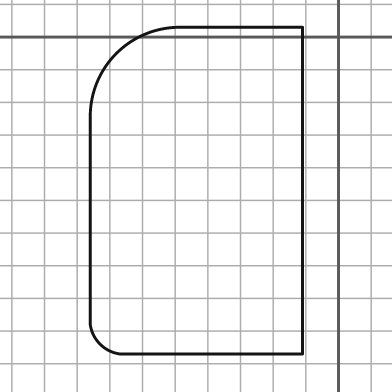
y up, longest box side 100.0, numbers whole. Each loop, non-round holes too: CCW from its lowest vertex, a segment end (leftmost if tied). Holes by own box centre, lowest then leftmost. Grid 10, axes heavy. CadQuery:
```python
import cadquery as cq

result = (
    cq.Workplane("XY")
    .moveTo(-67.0, -97.0)
    .lineTo(-11.0, -97.0)
    .lineTo(-11.0, 3.0)
    .lineTo(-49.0, 3.0)
    .threePointArc((-68.0, -5.0), (-76.0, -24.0))
    .lineTo(-76.0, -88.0)
    .threePointArc((-73.0, -94.0), (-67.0, -97.0))
    .close()
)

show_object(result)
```